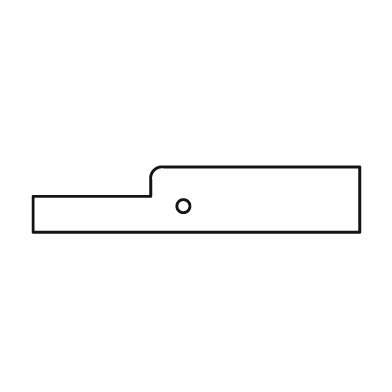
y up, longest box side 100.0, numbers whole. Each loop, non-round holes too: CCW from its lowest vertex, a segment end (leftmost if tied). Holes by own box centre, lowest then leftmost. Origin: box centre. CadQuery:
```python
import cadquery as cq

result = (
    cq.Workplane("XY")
    .moveTo(-50.0, -10.0)
    .lineTo(50.0, -10.0)
    .lineTo(50.0, 10.0)
    .lineTo(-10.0, 10.0)
    .threePointArc((-13.0, 9.0), (-14.0, 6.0))
    .lineTo(-14.0, 1.0)
    .lineTo(-50.0, 1.0)
    .close()
    .moveTo(-4.0, -2.0)
    .circle(2.0)
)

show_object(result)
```